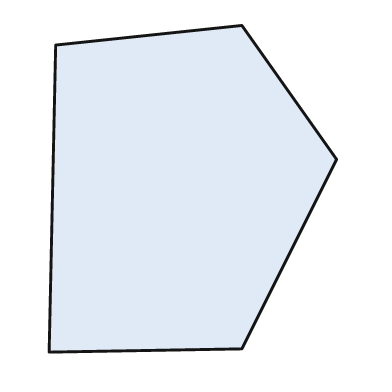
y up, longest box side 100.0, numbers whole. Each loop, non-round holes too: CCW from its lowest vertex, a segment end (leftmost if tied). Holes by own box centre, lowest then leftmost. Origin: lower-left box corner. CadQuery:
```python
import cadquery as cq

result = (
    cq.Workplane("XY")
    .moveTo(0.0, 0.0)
    .lineTo(59.0, 1.0)
    .lineTo(88.0, 59.0)
    .lineTo(59.0, 100.0)
    .lineTo(2.0, 94.0)
    .close()
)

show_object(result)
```